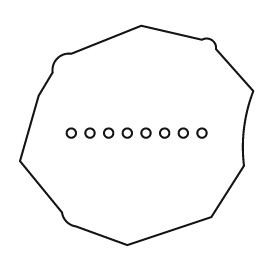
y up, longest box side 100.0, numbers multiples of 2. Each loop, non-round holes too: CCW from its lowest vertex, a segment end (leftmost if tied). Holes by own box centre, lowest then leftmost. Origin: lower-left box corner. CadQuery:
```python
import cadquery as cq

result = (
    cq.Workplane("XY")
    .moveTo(46.0, 0.0)
    .lineTo(82.0, 12.0)
    .lineTo(96.0, 34.0)
    .threePointArc((96.0, 50.0), (100.0, 66.0))
    .lineTo(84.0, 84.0)
    .threePointArc((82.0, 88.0), (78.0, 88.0))
    .lineTo(52.0, 94.0)
    .lineTo(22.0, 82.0)
    .threePointArc((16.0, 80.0), (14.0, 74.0))
    .lineTo(8.0, 64.0)
    .lineTo(0.0, 36.0)
    .lineTo(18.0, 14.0)
    .threePointArc((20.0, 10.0), (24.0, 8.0))
    .close()
    .moveTo(22.0, 48.0)
    .circle(2.0)
    .moveTo(30.0, 48.0)
    .circle(2.0)
    .moveTo(38.0, 48.0)
    .circle(2.0)
    .moveTo(46.0, 48.0)
    .circle(2.0)
    .moveTo(54.0, 48.0)
    .circle(2.0)
    .moveTo(62.0, 48.0)
    .circle(2.0)
    .moveTo(70.0, 48.0)
    .circle(2.0)
    .moveTo(78.0, 48.0)
    .circle(2.0)
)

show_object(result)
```